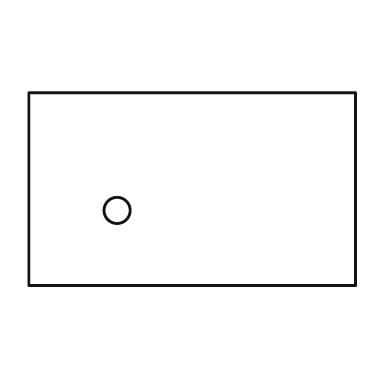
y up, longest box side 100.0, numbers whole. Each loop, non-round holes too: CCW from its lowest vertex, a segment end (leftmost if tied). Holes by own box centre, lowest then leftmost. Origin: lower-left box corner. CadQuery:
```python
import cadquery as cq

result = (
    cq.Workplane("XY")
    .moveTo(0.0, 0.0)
    .lineTo(100.0, 0.0)
    .lineTo(100.0, 59.0)
    .lineTo(0.0, 59.0)
    .close()
    .moveTo(27.0, 23.0)
    .circle(4.0)
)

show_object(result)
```